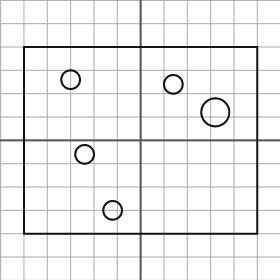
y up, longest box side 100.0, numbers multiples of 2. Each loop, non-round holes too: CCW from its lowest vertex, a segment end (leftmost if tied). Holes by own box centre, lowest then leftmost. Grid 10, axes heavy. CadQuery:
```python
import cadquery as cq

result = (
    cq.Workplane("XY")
    .moveTo(-50.0, -40.0)
    .lineTo(50.0, -40.0)
    .lineTo(50.0, 40.0)
    .lineTo(-50.0, 40.0)
    .close()
    .moveTo(-12.0, -30.0)
    .circle(4.0)
    .moveTo(-24.0, -6.0)
    .circle(4.0)
    .moveTo(32.0, 12.0)
    .circle(6.0)
    .moveTo(14.0, 24.0)
    .circle(4.0)
    .moveTo(-30.0, 26.0)
    .circle(4.0)
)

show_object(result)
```